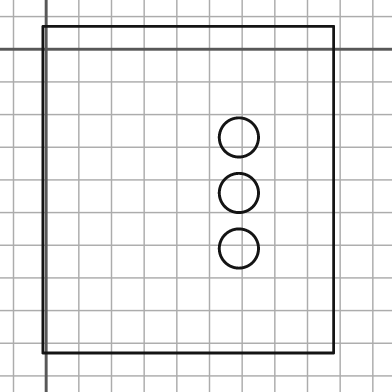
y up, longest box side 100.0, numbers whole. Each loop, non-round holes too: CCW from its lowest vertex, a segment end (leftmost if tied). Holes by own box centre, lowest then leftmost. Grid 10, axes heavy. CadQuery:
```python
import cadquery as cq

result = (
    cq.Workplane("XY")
    .moveTo(-1.0, -93.0)
    .lineTo(88.0, -93.0)
    .lineTo(88.0, 7.0)
    .lineTo(-1.0, 7.0)
    .close()
    .moveTo(59.0, -61.0)
    .circle(6.0)
    .moveTo(59.0, -44.0)
    .circle(6.0)
    .moveTo(59.0, -27.0)
    .circle(6.0)
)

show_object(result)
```